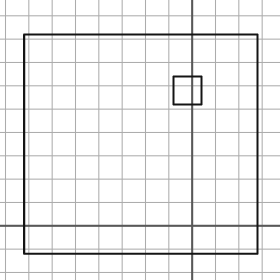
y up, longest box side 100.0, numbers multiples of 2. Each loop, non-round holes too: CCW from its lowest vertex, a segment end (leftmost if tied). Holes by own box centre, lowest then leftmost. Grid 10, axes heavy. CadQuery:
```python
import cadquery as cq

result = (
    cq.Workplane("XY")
    .moveTo(-72.0, -12.0)
    .lineTo(28.0, -12.0)
    .lineTo(28.0, 82.0)
    .lineTo(-72.0, 82.0)
    .close()
    .moveTo(-8.0, 52.0)
    .lineTo(4.0, 52.0)
    .lineTo(4.0, 64.0)
    .lineTo(-8.0, 64.0)
    .close()
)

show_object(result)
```